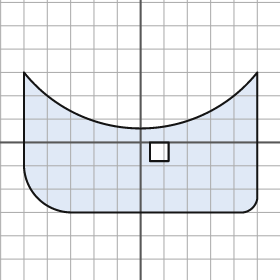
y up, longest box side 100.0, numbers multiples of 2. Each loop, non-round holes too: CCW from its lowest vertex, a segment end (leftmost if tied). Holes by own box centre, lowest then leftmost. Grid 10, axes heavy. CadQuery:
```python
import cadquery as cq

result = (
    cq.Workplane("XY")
    .moveTo(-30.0, -30.0)
    .lineTo(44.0, -30.0)
    .threePointArc((48.0, -28.0), (50.0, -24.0))
    .lineTo(50.0, 30.0)
    .threePointArc((0.0, 6.0), (-50.0, 30.0))
    .lineTo(-50.0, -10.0)
    .threePointArc((-44.0, -24.0), (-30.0, -30.0))
    .close()
    .moveTo(4.0, -8.0)
    .lineTo(12.0, -8.0)
    .lineTo(12.0, 0.0)
    .lineTo(4.0, 0.0)
    .close()
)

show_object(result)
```